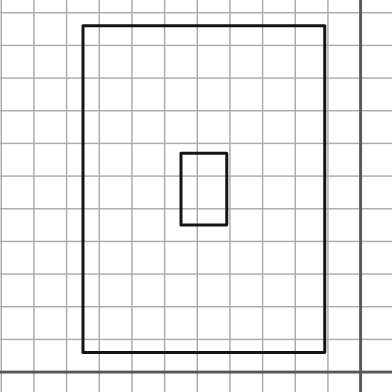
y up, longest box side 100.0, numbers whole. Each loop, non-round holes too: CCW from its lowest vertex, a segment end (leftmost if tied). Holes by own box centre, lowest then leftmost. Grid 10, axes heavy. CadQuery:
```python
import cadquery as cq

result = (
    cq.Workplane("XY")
    .moveTo(-85.0, 6.0)
    .lineTo(-11.0, 6.0)
    .lineTo(-11.0, 106.0)
    .lineTo(-85.0, 106.0)
    .close()
    .moveTo(-55.0, 45.0)
    .lineTo(-41.0, 45.0)
    .lineTo(-41.0, 67.0)
    .lineTo(-55.0, 67.0)
    .close()
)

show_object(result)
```